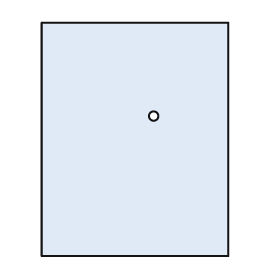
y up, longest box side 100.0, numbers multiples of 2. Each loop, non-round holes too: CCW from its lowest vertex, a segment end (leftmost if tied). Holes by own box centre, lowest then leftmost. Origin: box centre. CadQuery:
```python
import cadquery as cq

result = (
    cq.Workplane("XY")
    .moveTo(-40.0, -50.0)
    .lineTo(40.0, -50.0)
    .lineTo(40.0, 50.0)
    .lineTo(-40.0, 50.0)
    .close()
    .moveTo(8.0, 10.0)
    .circle(2.0)
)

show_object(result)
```